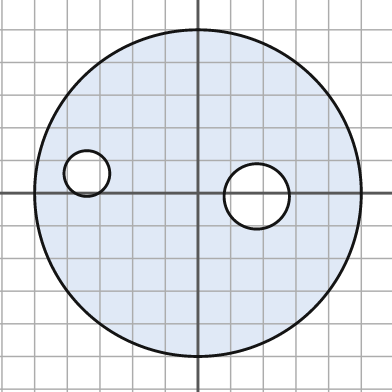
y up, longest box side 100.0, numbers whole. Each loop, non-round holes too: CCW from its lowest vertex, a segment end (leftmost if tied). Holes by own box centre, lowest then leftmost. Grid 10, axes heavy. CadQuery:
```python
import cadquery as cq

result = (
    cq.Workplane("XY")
    .moveTo(0.0, 0.0)
    .circle(50.0)
    .moveTo(18.0, -1.0)
    .circle(10.0)
    .moveTo(-34.0, 6.0)
    .circle(7.0)
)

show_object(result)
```